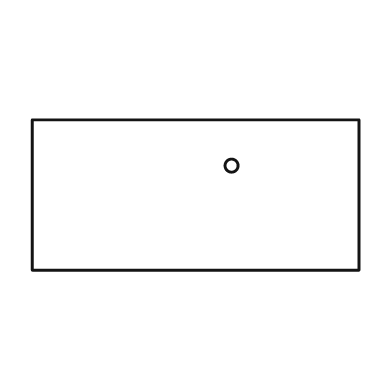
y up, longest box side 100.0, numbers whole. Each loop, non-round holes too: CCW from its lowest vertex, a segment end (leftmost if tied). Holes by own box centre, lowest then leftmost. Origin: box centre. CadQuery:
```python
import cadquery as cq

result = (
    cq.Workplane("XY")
    .moveTo(-50.0, -23.0)
    .lineTo(50.0, -23.0)
    .lineTo(50.0, 23.0)
    .lineTo(-50.0, 23.0)
    .close()
    .moveTo(11.0, 9.0)
    .circle(2.0)
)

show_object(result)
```